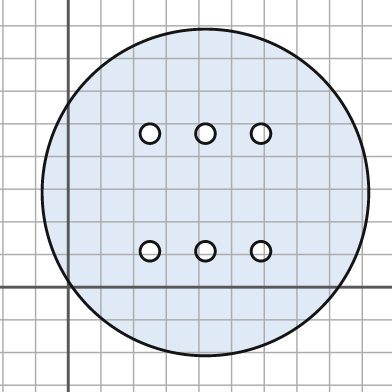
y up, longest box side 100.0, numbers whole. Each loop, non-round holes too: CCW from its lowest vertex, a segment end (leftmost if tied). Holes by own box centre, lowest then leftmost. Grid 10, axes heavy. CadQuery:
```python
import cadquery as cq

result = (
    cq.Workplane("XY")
    .moveTo(42.0, 29.0)
    .circle(50.0)
    .moveTo(25.0, 11.0)
    .circle(3.0)
    .moveTo(42.0, 11.0)
    .circle(3.0)
    .moveTo(59.0, 11.0)
    .circle(3.0)
    .moveTo(25.0, 47.0)
    .circle(3.0)
    .moveTo(42.0, 47.0)
    .circle(3.0)
    .moveTo(59.0, 47.0)
    .circle(3.0)
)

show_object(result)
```